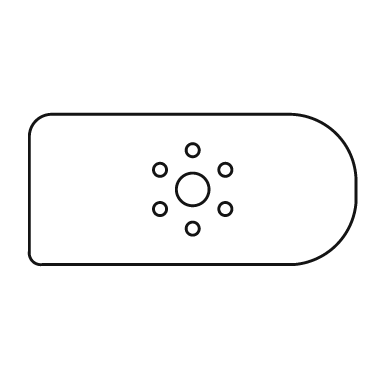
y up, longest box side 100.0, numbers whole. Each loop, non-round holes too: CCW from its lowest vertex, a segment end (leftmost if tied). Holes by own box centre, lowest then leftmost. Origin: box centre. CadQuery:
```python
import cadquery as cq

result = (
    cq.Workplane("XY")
    .moveTo(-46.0, -23.0)
    .lineTo(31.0, -23.0)
    .threePointArc((44.0, -17.0), (50.0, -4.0))
    .lineTo(50.0, 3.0)
    .threePointArc((44.0, 17.0), (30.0, 23.0))
    .lineTo(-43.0, 23.0)
    .threePointArc((-48.0, 21.0), (-50.0, 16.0))
    .lineTo(-50.0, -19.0)
    .threePointArc((-49.0, -22.0), (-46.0, -23.0))
    .close()
    .moveTo(0.0, -12.0)
    .circle(2.0)
    .moveTo(-10.0, -6.0)
    .circle(2.0)
    .moveTo(10.0, -6.0)
    .circle(2.0)
    .moveTo(0.0, 0.0)
    .circle(5.0)
    .moveTo(-10.0, 6.0)
    .circle(2.0)
    .moveTo(10.0, 6.0)
    .circle(2.0)
    .moveTo(0.0, 12.0)
    .circle(2.0)
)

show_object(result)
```